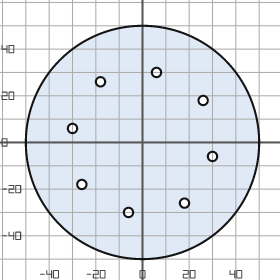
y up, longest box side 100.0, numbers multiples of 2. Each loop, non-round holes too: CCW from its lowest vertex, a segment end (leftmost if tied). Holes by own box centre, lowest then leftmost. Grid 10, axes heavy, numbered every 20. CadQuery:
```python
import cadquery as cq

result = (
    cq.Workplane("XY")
    .moveTo(0.0, 0.0)
    .circle(50.0)
    .moveTo(-6.0, -30.0)
    .circle(2.0)
    .moveTo(18.0, -26.0)
    .circle(2.0)
    .moveTo(-26.0, -18.0)
    .circle(2.0)
    .moveTo(30.0, -6.0)
    .circle(2.0)
    .moveTo(-30.0, 6.0)
    .circle(2.0)
    .moveTo(26.0, 18.0)
    .circle(2.0)
    .moveTo(-18.0, 26.0)
    .circle(2.0)
    .moveTo(6.0, 30.0)
    .circle(2.0)
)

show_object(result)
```